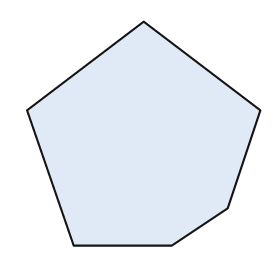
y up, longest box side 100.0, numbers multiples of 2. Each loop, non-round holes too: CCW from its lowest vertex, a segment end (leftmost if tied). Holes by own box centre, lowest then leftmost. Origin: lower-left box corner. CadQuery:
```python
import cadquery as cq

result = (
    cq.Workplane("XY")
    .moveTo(20.0, 0.0)
    .lineTo(62.0, 0.0)
    .lineTo(86.0, 16.0)
    .lineTo(100.0, 58.0)
    .lineTo(50.0, 96.0)
    .lineTo(0.0, 58.0)
    .close()
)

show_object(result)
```